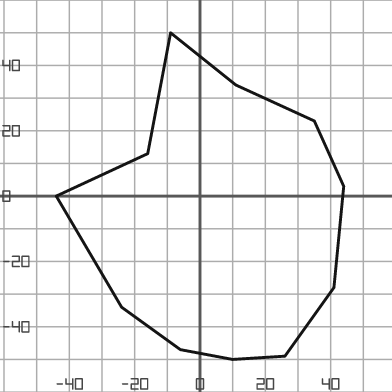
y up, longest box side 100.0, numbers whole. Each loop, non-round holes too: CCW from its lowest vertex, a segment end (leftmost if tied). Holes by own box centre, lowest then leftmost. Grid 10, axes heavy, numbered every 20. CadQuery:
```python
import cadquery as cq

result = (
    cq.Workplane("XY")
    .moveTo(10.0, -50.0)
    .lineTo(26.0, -49.0)
    .lineTo(41.0, -28.0)
    .lineTo(44.0, 3.0)
    .lineTo(35.0, 23.0)
    .lineTo(11.0, 34.0)
    .lineTo(-9.0, 50.0)
    .lineTo(-16.0, 13.0)
    .lineTo(-44.0, 0.0)
    .lineTo(-24.0, -34.0)
    .lineTo(-6.0, -47.0)
    .close()
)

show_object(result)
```